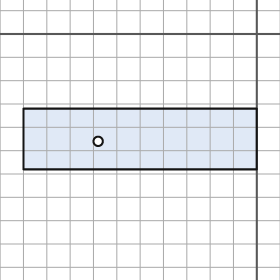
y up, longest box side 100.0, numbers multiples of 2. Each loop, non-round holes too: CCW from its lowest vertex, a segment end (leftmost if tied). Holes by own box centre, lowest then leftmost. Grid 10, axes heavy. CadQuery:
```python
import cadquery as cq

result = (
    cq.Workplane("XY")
    .moveTo(-100.0, -58.0)
    .lineTo(0.0, -58.0)
    .lineTo(0.0, -32.0)
    .lineTo(-100.0, -32.0)
    .close()
    .moveTo(-68.0, -46.0)
    .circle(2.0)
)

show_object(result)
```